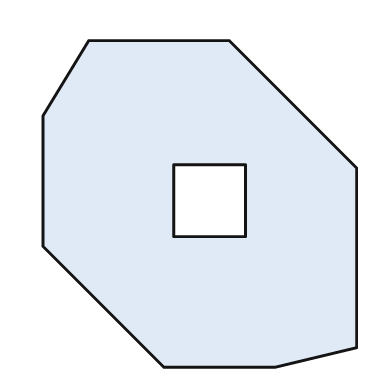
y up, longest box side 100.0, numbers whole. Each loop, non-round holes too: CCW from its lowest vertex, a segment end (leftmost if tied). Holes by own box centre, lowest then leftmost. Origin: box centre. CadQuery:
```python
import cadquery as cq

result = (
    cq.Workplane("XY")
    .moveTo(-11.0, -50.0)
    .lineTo(23.0, -50.0)
    .lineTo(48.0, -44.0)
    .lineTo(48.0, 11.0)
    .lineTo(9.0, 50.0)
    .lineTo(-34.0, 50.0)
    .lineTo(-48.0, 27.0)
    .lineTo(-48.0, -13.0)
    .close()
    .moveTo(-8.0, -10.0)
    .lineTo(14.0, -10.0)
    .lineTo(14.0, 12.0)
    .lineTo(-8.0, 12.0)
    .close()
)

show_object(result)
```